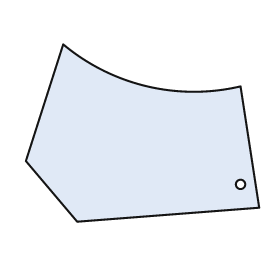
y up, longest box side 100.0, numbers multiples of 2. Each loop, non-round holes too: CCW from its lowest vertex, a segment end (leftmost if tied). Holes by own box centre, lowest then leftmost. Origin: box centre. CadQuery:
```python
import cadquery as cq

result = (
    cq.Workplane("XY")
    .moveTo(-28.0, -38.0)
    .lineTo(50.0, -32.0)
    .lineTo(42.0, 20.0)
    .threePointArc((2.0, 20.0), (-34.0, 38.0))
    .lineTo(-50.0, -12.0)
    .close()
    .moveTo(42.0, -22.0)
    .circle(2.0)
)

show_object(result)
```